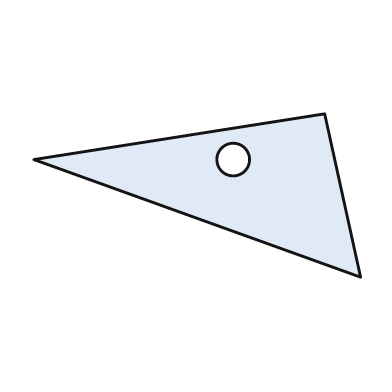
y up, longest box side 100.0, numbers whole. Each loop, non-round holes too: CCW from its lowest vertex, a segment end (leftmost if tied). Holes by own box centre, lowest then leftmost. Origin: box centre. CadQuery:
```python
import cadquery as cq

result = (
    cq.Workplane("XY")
    .moveTo(50.0, -25.0)
    .lineTo(39.0, 25.0)
    .lineTo(-50.0, 11.0)
    .close()
    .moveTo(11.0, 11.0)
    .circle(5.0)
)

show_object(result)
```